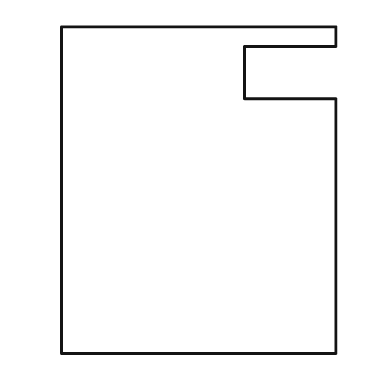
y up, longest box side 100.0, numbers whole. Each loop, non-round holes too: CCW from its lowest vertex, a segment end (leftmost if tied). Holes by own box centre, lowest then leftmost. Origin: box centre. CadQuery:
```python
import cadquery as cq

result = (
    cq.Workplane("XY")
    .moveTo(-42.0, -50.0)
    .lineTo(42.0, -50.0)
    .lineTo(42.0, 28.0)
    .lineTo(14.0, 28.0)
    .lineTo(14.0, 44.0)
    .lineTo(42.0, 44.0)
    .lineTo(42.0, 50.0)
    .lineTo(-42.0, 50.0)
    .close()
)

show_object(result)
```